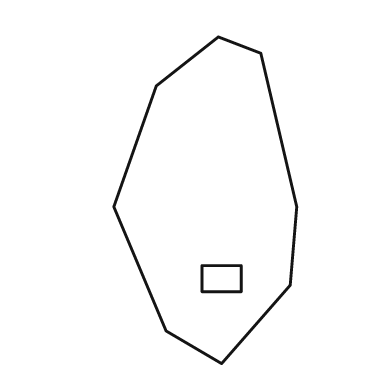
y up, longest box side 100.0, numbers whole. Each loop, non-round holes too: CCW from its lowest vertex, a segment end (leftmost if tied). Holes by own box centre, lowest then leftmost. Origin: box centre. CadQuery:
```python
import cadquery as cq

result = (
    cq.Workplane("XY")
    .moveTo(5.0, -50.0)
    .lineTo(26.0, -26.0)
    .lineTo(28.0, -2.0)
    .lineTo(17.0, 45.0)
    .lineTo(4.0, 50.0)
    .lineTo(-15.0, 35.0)
    .lineTo(-28.0, -2.0)
    .lineTo(-12.0, -40.0)
    .close()
    .moveTo(-1.0, -28.0)
    .lineTo(11.0, -28.0)
    .lineTo(11.0, -20.0)
    .lineTo(-1.0, -20.0)
    .close()
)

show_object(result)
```